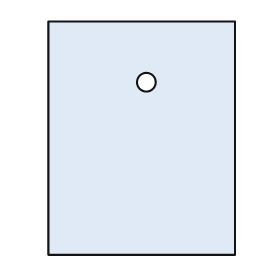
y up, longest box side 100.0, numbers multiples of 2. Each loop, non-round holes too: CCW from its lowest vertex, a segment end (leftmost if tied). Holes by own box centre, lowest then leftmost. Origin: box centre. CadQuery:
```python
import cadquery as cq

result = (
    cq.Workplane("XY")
    .moveTo(-40.0, -50.0)
    .lineTo(40.0, -50.0)
    .lineTo(40.0, 50.0)
    .lineTo(-40.0, 50.0)
    .close()
    .moveTo(2.0, 24.0)
    .circle(4.0)
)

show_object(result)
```